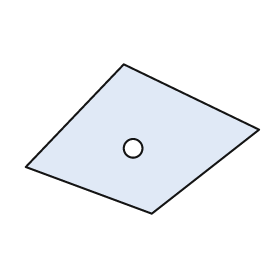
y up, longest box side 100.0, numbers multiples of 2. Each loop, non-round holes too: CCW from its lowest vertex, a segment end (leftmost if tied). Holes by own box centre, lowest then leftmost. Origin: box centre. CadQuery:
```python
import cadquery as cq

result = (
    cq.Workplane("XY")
    .moveTo(4.0, -32.0)
    .lineTo(50.0, 4.0)
    .lineTo(-8.0, 32.0)
    .lineTo(-50.0, -12.0)
    .close()
    .moveTo(-4.0, -4.0)
    .circle(4.0)
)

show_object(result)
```